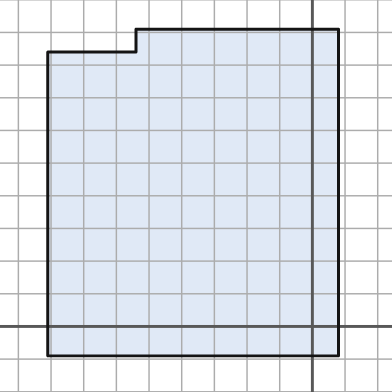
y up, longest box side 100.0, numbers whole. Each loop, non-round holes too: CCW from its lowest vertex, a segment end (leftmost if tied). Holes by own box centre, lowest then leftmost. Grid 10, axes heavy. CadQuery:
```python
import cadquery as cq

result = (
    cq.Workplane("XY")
    .moveTo(-81.0, -9.0)
    .lineTo(8.0, -9.0)
    .lineTo(8.0, 91.0)
    .lineTo(-54.0, 91.0)
    .lineTo(-54.0, 84.0)
    .lineTo(-81.0, 84.0)
    .close()
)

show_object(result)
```